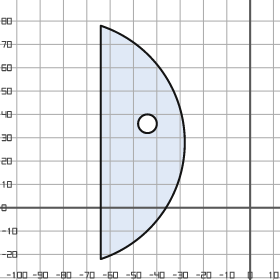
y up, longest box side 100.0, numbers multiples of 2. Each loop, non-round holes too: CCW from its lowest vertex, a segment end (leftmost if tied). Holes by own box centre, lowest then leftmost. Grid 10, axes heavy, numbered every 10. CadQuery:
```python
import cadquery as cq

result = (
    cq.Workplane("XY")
    .moveTo(-64.0, -22.0)
    .threePointArc((-28.0, 28.0), (-64.0, 78.0))
    .close()
    .moveTo(-44.0, 36.0)
    .circle(4.0)
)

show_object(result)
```